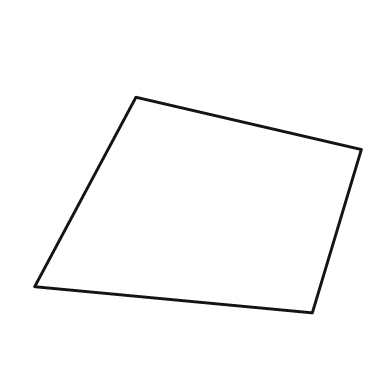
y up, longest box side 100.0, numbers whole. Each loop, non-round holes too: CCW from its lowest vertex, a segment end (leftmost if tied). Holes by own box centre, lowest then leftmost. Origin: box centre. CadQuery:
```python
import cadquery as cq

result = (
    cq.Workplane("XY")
    .moveTo(35.0, -33.0)
    .lineTo(50.0, 17.0)
    .lineTo(-19.0, 33.0)
    .lineTo(-50.0, -25.0)
    .close()
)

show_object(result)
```